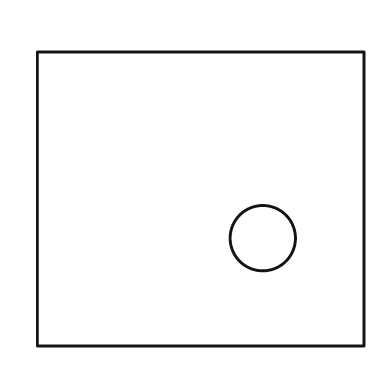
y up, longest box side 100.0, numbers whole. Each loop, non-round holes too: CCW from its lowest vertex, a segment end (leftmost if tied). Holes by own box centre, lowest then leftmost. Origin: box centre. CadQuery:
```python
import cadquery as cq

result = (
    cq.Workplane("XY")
    .moveTo(-50.0, -45.0)
    .lineTo(50.0, -45.0)
    .lineTo(50.0, 45.0)
    .lineTo(-50.0, 45.0)
    .close()
    .moveTo(19.0, -12.0)
    .circle(10.0)
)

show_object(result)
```